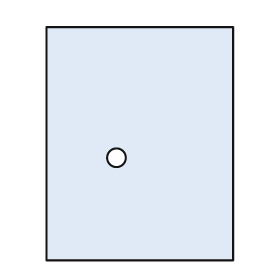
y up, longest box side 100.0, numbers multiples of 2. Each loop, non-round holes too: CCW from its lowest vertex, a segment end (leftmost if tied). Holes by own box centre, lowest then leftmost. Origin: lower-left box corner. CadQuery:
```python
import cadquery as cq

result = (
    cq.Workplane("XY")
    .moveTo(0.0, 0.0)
    .lineTo(80.0, 0.0)
    .lineTo(80.0, 100.0)
    .lineTo(0.0, 100.0)
    .close()
    .moveTo(30.0, 44.0)
    .circle(4.0)
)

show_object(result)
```